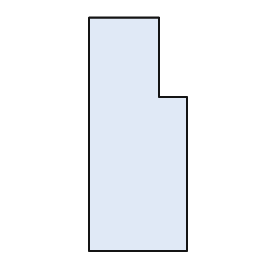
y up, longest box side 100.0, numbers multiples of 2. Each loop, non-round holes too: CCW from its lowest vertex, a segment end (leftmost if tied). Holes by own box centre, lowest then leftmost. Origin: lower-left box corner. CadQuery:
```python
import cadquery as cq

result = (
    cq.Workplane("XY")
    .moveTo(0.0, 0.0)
    .lineTo(42.0, 0.0)
    .lineTo(42.0, 66.0)
    .lineTo(30.0, 66.0)
    .lineTo(30.0, 100.0)
    .lineTo(0.0, 100.0)
    .close()
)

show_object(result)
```